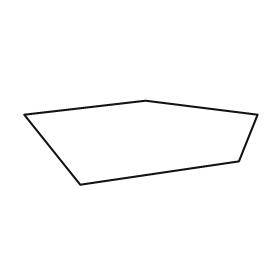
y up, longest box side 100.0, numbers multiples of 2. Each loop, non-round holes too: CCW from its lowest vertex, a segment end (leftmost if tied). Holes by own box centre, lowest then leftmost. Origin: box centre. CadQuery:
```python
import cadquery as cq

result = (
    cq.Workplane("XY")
    .moveTo(-26.0, -18.0)
    .lineTo(42.0, -8.0)
    .lineTo(50.0, 12.0)
    .lineTo(2.0, 18.0)
    .lineTo(-50.0, 12.0)
    .close()
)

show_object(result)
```